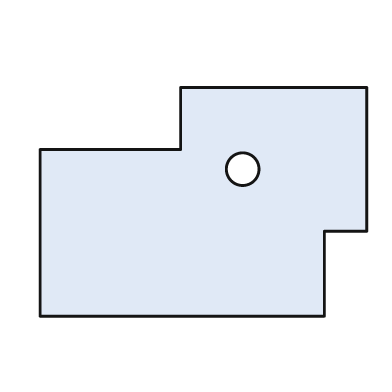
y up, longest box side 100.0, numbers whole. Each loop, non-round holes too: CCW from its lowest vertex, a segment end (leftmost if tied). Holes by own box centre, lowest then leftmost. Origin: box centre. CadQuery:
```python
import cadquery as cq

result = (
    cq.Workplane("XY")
    .moveTo(-50.0, -35.0)
    .lineTo(37.0, -35.0)
    .lineTo(37.0, -9.0)
    .lineTo(50.0, -9.0)
    .lineTo(50.0, 35.0)
    .lineTo(-7.0, 35.0)
    .lineTo(-7.0, 16.0)
    .lineTo(-50.0, 16.0)
    .close()
    .moveTo(12.0, 10.0)
    .circle(5.0)
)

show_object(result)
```